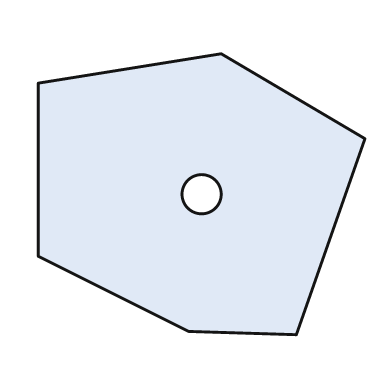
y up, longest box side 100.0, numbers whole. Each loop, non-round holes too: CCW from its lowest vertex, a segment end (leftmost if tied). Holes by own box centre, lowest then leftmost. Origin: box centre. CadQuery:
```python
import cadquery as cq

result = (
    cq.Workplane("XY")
    .moveTo(29.0, -43.0)
    .lineTo(50.0, 17.0)
    .lineTo(6.0, 43.0)
    .lineTo(-50.0, 34.0)
    .lineTo(-50.0, -19.0)
    .lineTo(-4.0, -42.0)
    .close()
    .moveTo(0.0, 0.0)
    .circle(6.0)
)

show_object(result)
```